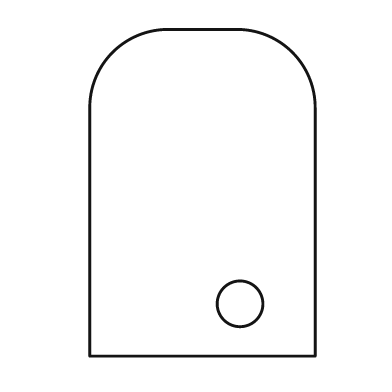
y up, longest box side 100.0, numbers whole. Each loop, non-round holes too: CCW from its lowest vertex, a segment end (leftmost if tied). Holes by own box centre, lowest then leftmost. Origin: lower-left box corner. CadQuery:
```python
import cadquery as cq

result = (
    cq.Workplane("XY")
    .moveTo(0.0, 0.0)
    .lineTo(69.0, 0.0)
    .lineTo(69.0, 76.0)
    .threePointArc((62.0, 93.0), (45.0, 100.0))
    .lineTo(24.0, 100.0)
    .threePointArc((7.0, 93.0), (0.0, 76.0))
    .close()
    .moveTo(46.0, 16.0)
    .circle(7.0)
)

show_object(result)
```